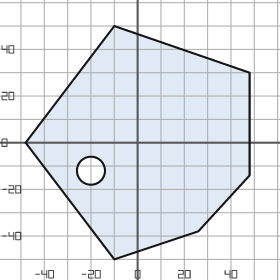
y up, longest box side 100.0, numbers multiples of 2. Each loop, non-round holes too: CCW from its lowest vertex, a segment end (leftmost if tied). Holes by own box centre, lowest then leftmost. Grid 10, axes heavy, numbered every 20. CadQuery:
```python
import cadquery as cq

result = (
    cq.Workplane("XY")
    .moveTo(-10.0, -50.0)
    .lineTo(26.0, -38.0)
    .lineTo(48.0, -14.0)
    .lineTo(48.0, 30.0)
    .lineTo(-10.0, 50.0)
    .lineTo(-48.0, 0.0)
    .close()
    .moveTo(-20.0, -12.0)
    .circle(6.0)
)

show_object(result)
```